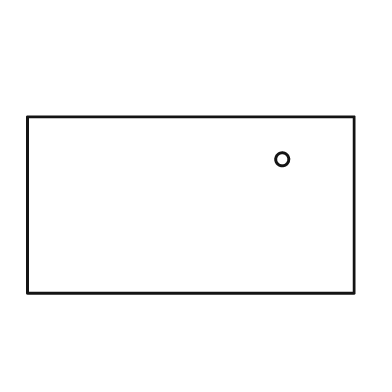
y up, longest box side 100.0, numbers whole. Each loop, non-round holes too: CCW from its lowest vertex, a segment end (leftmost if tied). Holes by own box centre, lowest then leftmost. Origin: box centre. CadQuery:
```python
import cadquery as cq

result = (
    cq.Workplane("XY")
    .moveTo(-50.0, -27.0)
    .lineTo(50.0, -27.0)
    .lineTo(50.0, 27.0)
    .lineTo(-50.0, 27.0)
    .close()
    .moveTo(28.0, 14.0)
    .circle(2.0)
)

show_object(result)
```